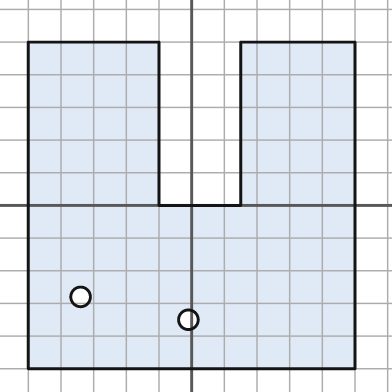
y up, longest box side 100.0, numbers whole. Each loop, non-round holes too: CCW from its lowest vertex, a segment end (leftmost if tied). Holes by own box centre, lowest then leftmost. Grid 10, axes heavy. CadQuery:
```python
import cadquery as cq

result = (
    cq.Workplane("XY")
    .moveTo(-50.0, -50.0)
    .lineTo(50.0, -50.0)
    .lineTo(50.0, 50.0)
    .lineTo(15.0, 50.0)
    .lineTo(15.0, 0.0)
    .lineTo(-10.0, 0.0)
    .lineTo(-10.0, 50.0)
    .lineTo(-50.0, 50.0)
    .close()
    .moveTo(-1.0, -35.0)
    .circle(3.0)
    .moveTo(-34.0, -28.0)
    .circle(3.0)
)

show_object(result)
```